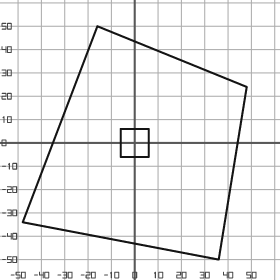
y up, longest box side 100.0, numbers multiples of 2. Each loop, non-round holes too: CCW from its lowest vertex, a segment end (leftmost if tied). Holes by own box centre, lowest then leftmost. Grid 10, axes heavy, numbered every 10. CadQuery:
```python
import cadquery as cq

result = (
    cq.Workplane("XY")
    .moveTo(36.0, -50.0)
    .lineTo(48.0, 24.0)
    .lineTo(-16.0, 50.0)
    .lineTo(-48.0, -34.0)
    .close()
    .moveTo(-6.0, -6.0)
    .lineTo(6.0, -6.0)
    .lineTo(6.0, 6.0)
    .lineTo(-6.0, 6.0)
    .close()
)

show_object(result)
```